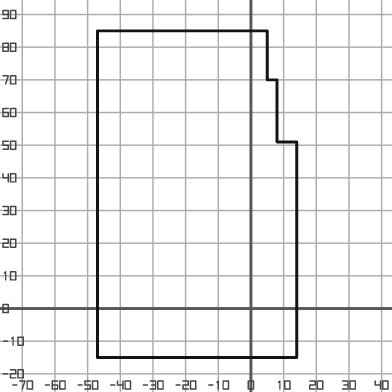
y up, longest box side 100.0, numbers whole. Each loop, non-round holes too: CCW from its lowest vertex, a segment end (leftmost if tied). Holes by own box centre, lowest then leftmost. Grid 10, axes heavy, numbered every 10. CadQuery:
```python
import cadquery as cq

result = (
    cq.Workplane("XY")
    .moveTo(-47.0, -15.0)
    .lineTo(14.0, -15.0)
    .lineTo(14.0, 51.0)
    .lineTo(8.0, 51.0)
    .lineTo(8.0, 70.0)
    .lineTo(5.0, 70.0)
    .lineTo(5.0, 85.0)
    .lineTo(-47.0, 85.0)
    .close()
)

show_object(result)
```